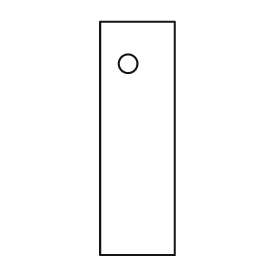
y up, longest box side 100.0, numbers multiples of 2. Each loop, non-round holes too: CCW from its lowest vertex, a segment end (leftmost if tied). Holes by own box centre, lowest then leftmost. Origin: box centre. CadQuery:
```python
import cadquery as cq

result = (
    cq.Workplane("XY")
    .moveTo(-16.0, -50.0)
    .lineTo(16.0, -50.0)
    .lineTo(16.0, 50.0)
    .lineTo(-16.0, 50.0)
    .close()
    .moveTo(-4.0, 32.0)
    .circle(4.0)
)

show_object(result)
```